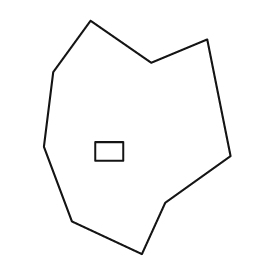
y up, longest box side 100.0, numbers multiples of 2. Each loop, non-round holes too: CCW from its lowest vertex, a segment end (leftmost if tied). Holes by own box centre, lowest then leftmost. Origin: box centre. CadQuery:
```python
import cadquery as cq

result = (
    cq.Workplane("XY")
    .moveTo(2.0, -50.0)
    .lineTo(12.0, -28.0)
    .lineTo(40.0, -8.0)
    .lineTo(30.0, 42.0)
    .lineTo(6.0, 32.0)
    .lineTo(-20.0, 50.0)
    .lineTo(-36.0, 28.0)
    .lineTo(-40.0, -4.0)
    .lineTo(-28.0, -36.0)
    .close()
    .moveTo(-18.0, -10.0)
    .lineTo(-6.0, -10.0)
    .lineTo(-6.0, -2.0)
    .lineTo(-18.0, -2.0)
    .close()
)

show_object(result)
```